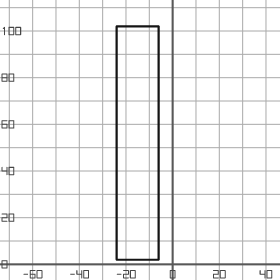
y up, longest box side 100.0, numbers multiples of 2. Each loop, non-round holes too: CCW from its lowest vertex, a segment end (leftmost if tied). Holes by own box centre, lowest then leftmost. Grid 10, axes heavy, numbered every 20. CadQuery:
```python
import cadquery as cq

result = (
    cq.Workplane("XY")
    .moveTo(-24.0, 2.0)
    .lineTo(-6.0, 2.0)
    .lineTo(-6.0, 102.0)
    .lineTo(-24.0, 102.0)
    .close()
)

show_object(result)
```